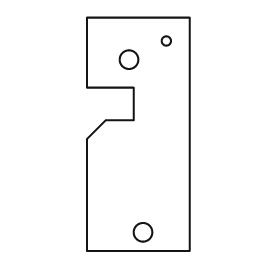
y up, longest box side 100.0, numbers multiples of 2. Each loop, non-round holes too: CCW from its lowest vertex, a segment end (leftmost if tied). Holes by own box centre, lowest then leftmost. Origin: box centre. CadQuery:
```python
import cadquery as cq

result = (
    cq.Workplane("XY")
    .moveTo(-22.0, -50.0)
    .lineTo(22.0, -50.0)
    .lineTo(22.0, 50.0)
    .lineTo(-22.0, 50.0)
    .lineTo(-22.0, 20.0)
    .lineTo(-2.0, 20.0)
    .lineTo(-2.0, 6.0)
    .lineTo(-14.0, 6.0)
    .lineTo(-22.0, -2.0)
    .close()
    .moveTo(2.0, -42.0)
    .circle(4.0)
    .moveTo(-4.0, 32.0)
    .circle(4.0)
    .moveTo(12.0, 40.0)
    .circle(2.0)
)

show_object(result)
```